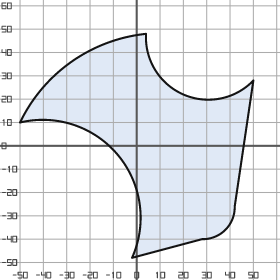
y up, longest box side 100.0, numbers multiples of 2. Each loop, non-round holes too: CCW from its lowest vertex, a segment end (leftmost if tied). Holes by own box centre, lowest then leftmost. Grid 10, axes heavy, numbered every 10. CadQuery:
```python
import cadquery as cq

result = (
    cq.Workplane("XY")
    .moveTo(-2.0, -48.0)
    .lineTo(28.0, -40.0)
    .threePointArc((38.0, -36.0), (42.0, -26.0))
    .lineTo(50.0, 28.0)
    .threePointArc((20.0, 22.0), (4.0, 48.0))
    .threePointArc((-28.0, 36.0), (-50.0, 10.0))
    .threePointArc((-8.0, -4.0), (-2.0, -48.0))
    .close()
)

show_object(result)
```